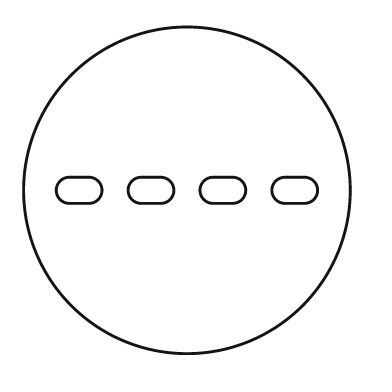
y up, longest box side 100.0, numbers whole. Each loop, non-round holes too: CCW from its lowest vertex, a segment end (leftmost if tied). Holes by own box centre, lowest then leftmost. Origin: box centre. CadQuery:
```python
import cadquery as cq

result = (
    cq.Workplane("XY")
    .moveTo(0.0, 0.0)
    .circle(50.0)
    .moveTo(-36.0, -4.0)
    .lineTo(-30.0, -4.0)
    .threePointArc((-26.0, 0.0), (-30.0, 4.0))
    .lineTo(-36.0, 4.0)
    .threePointArc((-40.0, 0.0), (-36.0, -4.0))
    .close()
    .moveTo(-14.0, -4.0)
    .lineTo(-8.0, -4.0)
    .threePointArc((-4.0, 0.0), (-8.0, 4.0))
    .lineTo(-14.0, 4.0)
    .threePointArc((-18.0, 0.0), (-14.0, -4.0))
    .close()
    .moveTo(8.0, -4.0)
    .lineTo(14.0, -4.0)
    .threePointArc((18.0, 0.0), (14.0, 4.0))
    .lineTo(8.0, 4.0)
    .threePointArc((4.0, 0.0), (8.0, -4.0))
    .close()
    .moveTo(30.0, -4.0)
    .lineTo(36.0, -4.0)
    .threePointArc((40.0, 0.0), (36.0, 4.0))
    .lineTo(30.0, 4.0)
    .threePointArc((26.0, 0.0), (30.0, -4.0))
    .close()
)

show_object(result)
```